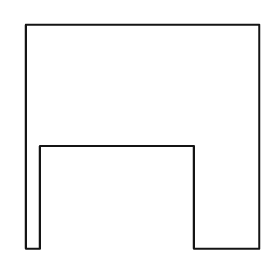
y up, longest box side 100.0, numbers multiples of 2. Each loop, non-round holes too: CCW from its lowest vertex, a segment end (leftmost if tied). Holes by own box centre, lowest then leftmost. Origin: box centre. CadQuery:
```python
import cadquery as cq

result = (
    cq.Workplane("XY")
    .moveTo(-50.0, -48.0)
    .lineTo(-44.0, -48.0)
    .lineTo(-44.0, -4.0)
    .lineTo(22.0, -4.0)
    .lineTo(22.0, -48.0)
    .lineTo(50.0, -48.0)
    .lineTo(50.0, 48.0)
    .lineTo(-50.0, 48.0)
    .close()
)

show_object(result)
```